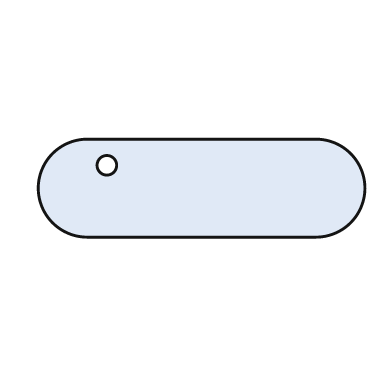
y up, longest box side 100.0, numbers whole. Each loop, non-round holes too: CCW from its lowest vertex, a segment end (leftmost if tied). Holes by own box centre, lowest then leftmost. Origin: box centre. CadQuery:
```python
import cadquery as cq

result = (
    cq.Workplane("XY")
    .moveTo(-35.0, -15.0)
    .lineTo(35.0, -15.0)
    .threePointArc((50.0, 0.0), (35.0, 15.0))
    .lineTo(-35.0, 15.0)
    .threePointArc((-50.0, 0.0), (-35.0, -15.0))
    .close()
    .moveTo(-29.0, 7.0)
    .circle(3.0)
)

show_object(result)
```